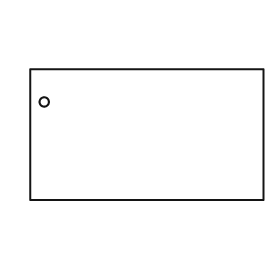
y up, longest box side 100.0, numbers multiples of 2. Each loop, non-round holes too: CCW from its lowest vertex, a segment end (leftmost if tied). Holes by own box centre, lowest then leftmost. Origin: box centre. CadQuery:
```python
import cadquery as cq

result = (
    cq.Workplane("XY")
    .moveTo(-50.0, -28.0)
    .lineTo(50.0, -28.0)
    .lineTo(50.0, 28.0)
    .lineTo(-50.0, 28.0)
    .close()
    .moveTo(-44.0, 14.0)
    .circle(2.0)
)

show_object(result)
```